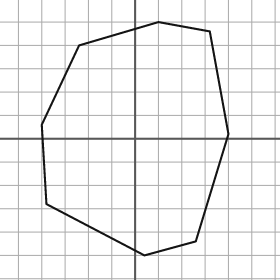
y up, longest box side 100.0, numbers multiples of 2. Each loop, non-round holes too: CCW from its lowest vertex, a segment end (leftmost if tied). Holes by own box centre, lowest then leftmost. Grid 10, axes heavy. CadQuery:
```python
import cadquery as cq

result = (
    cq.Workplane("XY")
    .moveTo(4.0, -50.0)
    .lineTo(26.0, -44.0)
    .lineTo(40.0, 2.0)
    .lineTo(32.0, 46.0)
    .lineTo(10.0, 50.0)
    .lineTo(-24.0, 40.0)
    .lineTo(-40.0, 6.0)
    .lineTo(-38.0, -28.0)
    .close()
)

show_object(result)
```